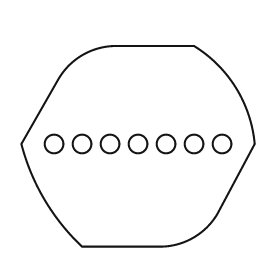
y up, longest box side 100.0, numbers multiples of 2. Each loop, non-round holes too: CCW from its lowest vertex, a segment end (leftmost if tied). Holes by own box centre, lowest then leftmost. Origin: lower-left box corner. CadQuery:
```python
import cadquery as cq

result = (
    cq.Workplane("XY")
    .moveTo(26.0, 0.0)
    .lineTo(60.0, 0.0)
    .threePointArc((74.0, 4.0), (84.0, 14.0))
    .lineTo(100.0, 44.0)
    .threePointArc((92.0, 68.0), (74.0, 86.0))
    .lineTo(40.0, 86.0)
    .threePointArc((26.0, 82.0), (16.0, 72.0))
    .lineTo(0.0, 44.0)
    .threePointArc((10.0, 20.0), (26.0, 0.0))
    .close()
    .moveTo(14.0, 44.0)
    .circle(4.0)
    .moveTo(26.0, 44.0)
    .circle(4.0)
    .moveTo(38.0, 44.0)
    .circle(4.0)
    .moveTo(50.0, 44.0)
    .circle(4.0)
    .moveTo(62.0, 44.0)
    .circle(4.0)
    .moveTo(74.0, 44.0)
    .circle(4.0)
    .moveTo(86.0, 44.0)
    .circle(4.0)
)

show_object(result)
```